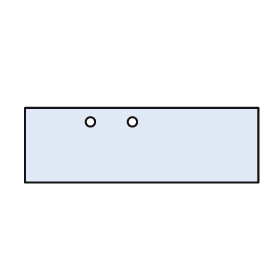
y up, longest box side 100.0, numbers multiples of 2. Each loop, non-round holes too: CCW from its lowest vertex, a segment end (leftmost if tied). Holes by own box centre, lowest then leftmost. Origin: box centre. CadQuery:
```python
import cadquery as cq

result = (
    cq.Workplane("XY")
    .moveTo(-50.0, -16.0)
    .lineTo(50.0, -16.0)
    .lineTo(50.0, 16.0)
    .lineTo(-50.0, 16.0)
    .close()
    .moveTo(-22.0, 10.0)
    .circle(2.0)
    .moveTo(-4.0, 10.0)
    .circle(2.0)
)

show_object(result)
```